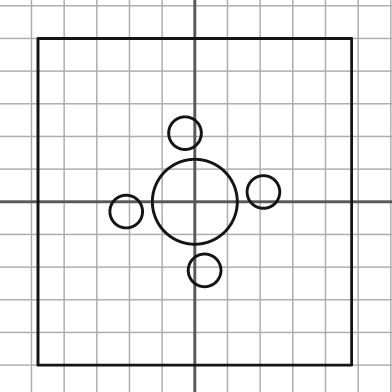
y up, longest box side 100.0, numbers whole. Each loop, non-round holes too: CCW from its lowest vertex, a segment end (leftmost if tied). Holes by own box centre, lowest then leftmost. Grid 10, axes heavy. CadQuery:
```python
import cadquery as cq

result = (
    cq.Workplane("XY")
    .moveTo(-48.0, -50.0)
    .lineTo(48.0, -50.0)
    .lineTo(48.0, 50.0)
    .lineTo(-48.0, 50.0)
    .close()
    .moveTo(3.0, -21.0)
    .circle(5.0)
    .moveTo(-21.0, -3.0)
    .circle(5.0)
    .moveTo(0.0, 0.0)
    .circle(13.0)
    .moveTo(21.0, 3.0)
    .circle(5.0)
    .moveTo(-3.0, 21.0)
    .circle(5.0)
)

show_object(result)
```